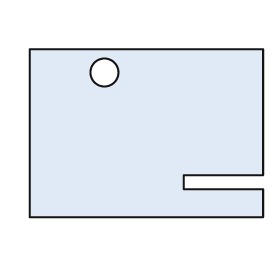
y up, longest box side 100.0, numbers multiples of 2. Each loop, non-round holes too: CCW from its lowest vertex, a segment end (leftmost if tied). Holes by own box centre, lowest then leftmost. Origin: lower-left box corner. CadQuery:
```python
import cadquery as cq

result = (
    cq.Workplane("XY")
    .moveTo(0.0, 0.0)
    .lineTo(100.0, 0.0)
    .lineTo(100.0, 12.0)
    .lineTo(66.0, 12.0)
    .lineTo(66.0, 18.0)
    .lineTo(100.0, 18.0)
    .lineTo(100.0, 72.0)
    .lineTo(0.0, 72.0)
    .close()
    .moveTo(32.0, 62.0)
    .circle(6.0)
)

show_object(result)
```